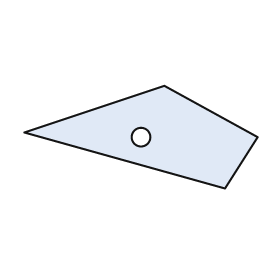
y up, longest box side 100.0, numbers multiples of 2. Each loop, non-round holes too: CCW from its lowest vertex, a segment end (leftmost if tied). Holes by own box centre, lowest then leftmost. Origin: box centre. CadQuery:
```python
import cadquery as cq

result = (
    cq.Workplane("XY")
    .moveTo(36.0, -22.0)
    .lineTo(50.0, 0.0)
    .lineTo(10.0, 22.0)
    .lineTo(-50.0, 2.0)
    .close()
    .moveTo(0.0, 0.0)
    .circle(4.0)
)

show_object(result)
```